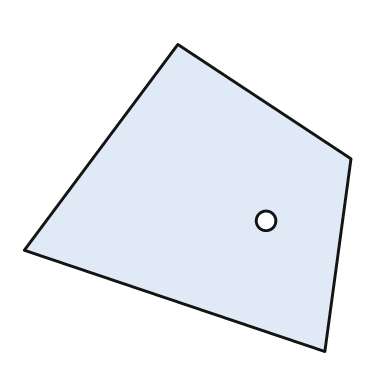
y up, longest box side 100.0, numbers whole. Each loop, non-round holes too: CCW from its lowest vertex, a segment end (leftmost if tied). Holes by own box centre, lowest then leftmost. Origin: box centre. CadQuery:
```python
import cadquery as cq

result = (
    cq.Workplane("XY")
    .moveTo(42.0, -47.0)
    .lineTo(50.0, 12.0)
    .lineTo(-3.0, 47.0)
    .lineTo(-50.0, -16.0)
    .close()
    .moveTo(24.0, -7.0)
    .circle(3.0)
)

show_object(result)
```